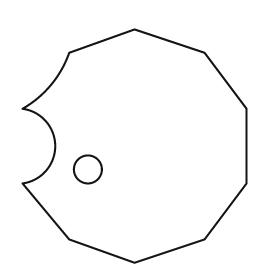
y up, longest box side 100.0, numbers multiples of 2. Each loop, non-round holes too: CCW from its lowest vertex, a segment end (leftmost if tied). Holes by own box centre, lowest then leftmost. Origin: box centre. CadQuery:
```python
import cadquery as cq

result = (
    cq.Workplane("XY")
    .moveTo(0.0, -50.0)
    .lineTo(30.0, -40.0)
    .lineTo(48.0, -16.0)
    .lineTo(48.0, 16.0)
    .lineTo(30.0, 40.0)
    .lineTo(0.0, 50.0)
    .lineTo(-28.0, 40.0)
    .threePointArc((-36.0, 26.0), (-48.0, 16.0))
    .threePointArc((-34.0, 0.0), (-48.0, -16.0))
    .lineTo(-28.0, -40.0)
    .close()
    .moveTo(-20.0, -10.0)
    .circle(6.0)
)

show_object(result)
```